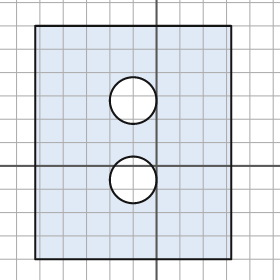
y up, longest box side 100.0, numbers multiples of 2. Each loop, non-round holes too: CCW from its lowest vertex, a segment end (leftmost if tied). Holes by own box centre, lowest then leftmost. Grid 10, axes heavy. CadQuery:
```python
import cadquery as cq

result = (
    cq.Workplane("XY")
    .moveTo(-52.0, -40.0)
    .lineTo(32.0, -40.0)
    .lineTo(32.0, 60.0)
    .lineTo(-52.0, 60.0)
    .close()
    .moveTo(-10.0, -6.0)
    .circle(10.0)
    .moveTo(-10.0, 28.0)
    .circle(10.0)
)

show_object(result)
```